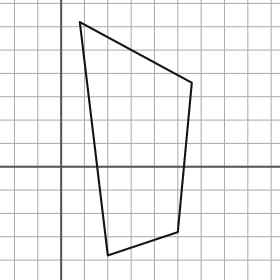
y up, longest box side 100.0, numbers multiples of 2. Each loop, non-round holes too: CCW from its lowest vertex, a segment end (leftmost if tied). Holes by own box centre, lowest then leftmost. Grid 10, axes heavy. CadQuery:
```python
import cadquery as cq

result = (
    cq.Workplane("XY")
    .moveTo(20.0, -38.0)
    .lineTo(50.0, -28.0)
    .lineTo(56.0, 36.0)
    .lineTo(8.0, 62.0)
    .close()
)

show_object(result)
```